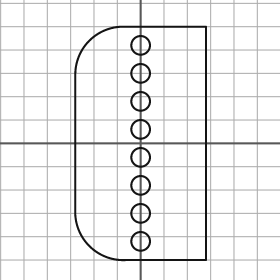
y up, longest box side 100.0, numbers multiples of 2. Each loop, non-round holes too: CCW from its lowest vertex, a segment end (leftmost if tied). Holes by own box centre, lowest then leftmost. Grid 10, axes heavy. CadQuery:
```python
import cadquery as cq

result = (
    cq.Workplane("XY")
    .moveTo(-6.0, -50.0)
    .lineTo(28.0, -50.0)
    .lineTo(28.0, 50.0)
    .lineTo(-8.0, 50.0)
    .threePointArc((-22.0, 44.0), (-28.0, 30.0))
    .lineTo(-28.0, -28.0)
    .threePointArc((-22.0, -44.0), (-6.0, -50.0))
    .close()
    .moveTo(0.0, -42.0)
    .circle(4.0)
    .moveTo(0.0, -30.0)
    .circle(4.0)
    .moveTo(0.0, -18.0)
    .circle(4.0)
    .moveTo(0.0, -6.0)
    .circle(4.0)
    .moveTo(0.0, 6.0)
    .circle(4.0)
    .moveTo(0.0, 18.0)
    .circle(4.0)
    .moveTo(0.0, 30.0)
    .circle(4.0)
    .moveTo(0.0, 42.0)
    .circle(4.0)
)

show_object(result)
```